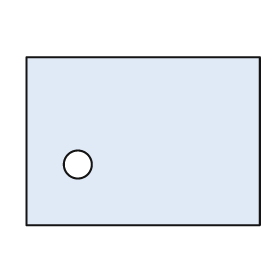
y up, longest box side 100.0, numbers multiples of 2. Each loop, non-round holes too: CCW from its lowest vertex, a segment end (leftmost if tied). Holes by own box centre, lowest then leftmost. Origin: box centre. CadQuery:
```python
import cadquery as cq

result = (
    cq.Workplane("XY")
    .moveTo(-50.0, -36.0)
    .lineTo(50.0, -36.0)
    .lineTo(50.0, 36.0)
    .lineTo(-50.0, 36.0)
    .close()
    .moveTo(-28.0, -10.0)
    .circle(6.0)
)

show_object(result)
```